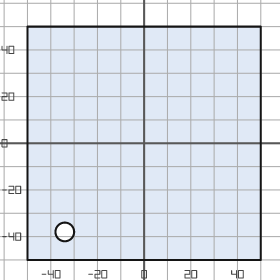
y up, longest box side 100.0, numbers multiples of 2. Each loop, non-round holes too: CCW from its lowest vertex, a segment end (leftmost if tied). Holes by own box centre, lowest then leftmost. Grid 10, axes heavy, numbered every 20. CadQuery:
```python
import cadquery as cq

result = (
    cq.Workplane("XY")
    .moveTo(-50.0, -50.0)
    .lineTo(50.0, -50.0)
    .lineTo(50.0, 50.0)
    .lineTo(-50.0, 50.0)
    .close()
    .moveTo(-34.0, -38.0)
    .circle(4.0)
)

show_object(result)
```